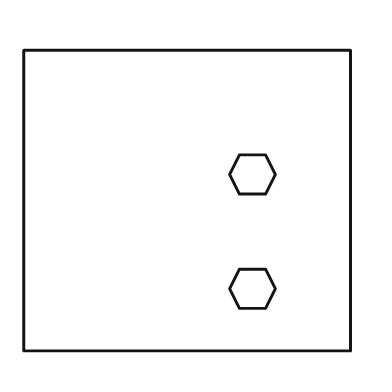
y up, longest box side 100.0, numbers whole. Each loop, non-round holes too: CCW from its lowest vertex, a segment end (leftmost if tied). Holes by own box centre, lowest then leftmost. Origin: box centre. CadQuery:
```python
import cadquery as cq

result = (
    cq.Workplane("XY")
    .moveTo(-50.0, -46.0)
    .lineTo(50.0, -46.0)
    .lineTo(50.0, 46.0)
    .lineTo(-50.0, 46.0)
    .close()
    .moveTo(16.0, -33.0)
    .lineTo(24.0, -33.0)
    .lineTo(27.0, -27.0)
    .lineTo(24.0, -21.0)
    .lineTo(16.0, -21.0)
    .lineTo(13.0, -27.0)
    .close()
    .moveTo(16.0, 2.0)
    .lineTo(24.0, 2.0)
    .lineTo(27.0, 8.0)
    .lineTo(24.0, 14.0)
    .lineTo(16.0, 14.0)
    .lineTo(13.0, 8.0)
    .close()
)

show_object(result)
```